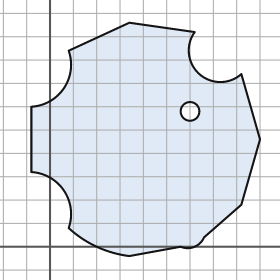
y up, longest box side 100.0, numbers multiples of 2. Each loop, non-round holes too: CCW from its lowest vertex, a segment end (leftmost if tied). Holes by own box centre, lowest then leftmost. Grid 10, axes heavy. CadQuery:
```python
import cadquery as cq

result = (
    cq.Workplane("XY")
    .moveTo(34.0, -4.0)
    .lineTo(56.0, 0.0)
    .threePointArc((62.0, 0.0), (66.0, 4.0))
    .lineTo(82.0, 18.0)
    .lineTo(90.0, 46.0)
    .lineTo(82.0, 74.0)
    .threePointArc((64.0, 74.0), (62.0, 92.0))
    .lineTo(34.0, 96.0)
    .lineTo(8.0, 84.0)
    .threePointArc((6.0, 68.0), (-8.0, 60.0))
    .lineTo(-8.0, 32.0)
    .threePointArc((6.0, 24.0), (8.0, 8.0))
    .threePointArc((20.0, 0.0), (34.0, -4.0))
    .close()
    .moveTo(60.0, 58.0)
    .circle(4.0)
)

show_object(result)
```